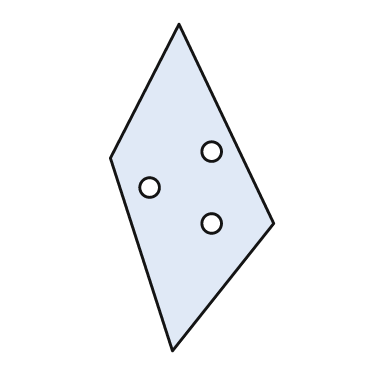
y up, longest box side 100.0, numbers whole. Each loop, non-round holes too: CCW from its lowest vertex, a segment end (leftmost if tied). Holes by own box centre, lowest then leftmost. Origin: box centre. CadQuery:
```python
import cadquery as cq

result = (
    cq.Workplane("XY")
    .moveTo(-6.0, -50.0)
    .lineTo(25.0, -11.0)
    .lineTo(-4.0, 50.0)
    .lineTo(-25.0, 9.0)
    .close()
    .moveTo(6.0, -11.0)
    .circle(3.0)
    .moveTo(-13.0, 0.0)
    .circle(3.0)
    .moveTo(6.0, 11.0)
    .circle(3.0)
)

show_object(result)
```